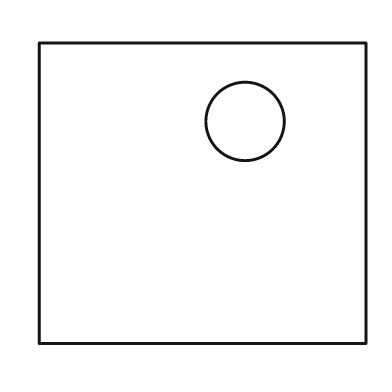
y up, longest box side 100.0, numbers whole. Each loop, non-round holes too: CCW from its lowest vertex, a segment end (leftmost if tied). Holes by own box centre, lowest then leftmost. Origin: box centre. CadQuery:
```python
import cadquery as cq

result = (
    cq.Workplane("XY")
    .moveTo(-50.0, -46.0)
    .lineTo(50.0, -46.0)
    .lineTo(50.0, 46.0)
    .lineTo(-50.0, 46.0)
    .close()
    .moveTo(13.0, 22.0)
    .circle(12.0)
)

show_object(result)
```